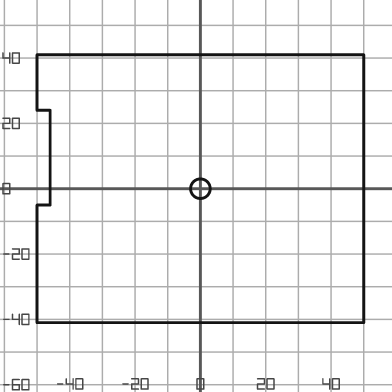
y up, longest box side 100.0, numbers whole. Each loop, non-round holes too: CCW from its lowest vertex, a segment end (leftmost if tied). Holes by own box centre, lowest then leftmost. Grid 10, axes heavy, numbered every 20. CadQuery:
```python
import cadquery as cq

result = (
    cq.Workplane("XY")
    .moveTo(-50.0, -41.0)
    .lineTo(50.0, -41.0)
    .lineTo(50.0, 41.0)
    .lineTo(-50.0, 41.0)
    .lineTo(-50.0, 24.0)
    .lineTo(-46.0, 24.0)
    .lineTo(-46.0, -5.0)
    .lineTo(-50.0, -5.0)
    .close()
    .moveTo(0.0, 0.0)
    .circle(3.0)
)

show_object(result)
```